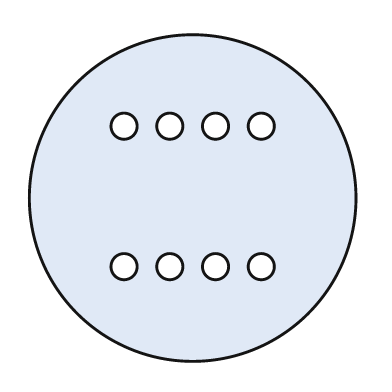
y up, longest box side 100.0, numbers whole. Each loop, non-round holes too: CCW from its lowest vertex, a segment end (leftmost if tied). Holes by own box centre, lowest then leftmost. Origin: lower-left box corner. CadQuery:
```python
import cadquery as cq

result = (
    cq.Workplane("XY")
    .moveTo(50.0, 50.0)
    .circle(50.0)
    .moveTo(29.0, 29.0)
    .circle(4.0)
    .moveTo(43.0, 29.0)
    .circle(4.0)
    .moveTo(57.0, 29.0)
    .circle(4.0)
    .moveTo(71.0, 29.0)
    .circle(4.0)
    .moveTo(29.0, 72.0)
    .circle(4.0)
    .moveTo(43.0, 72.0)
    .circle(4.0)
    .moveTo(57.0, 72.0)
    .circle(4.0)
    .moveTo(71.0, 72.0)
    .circle(4.0)
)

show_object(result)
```